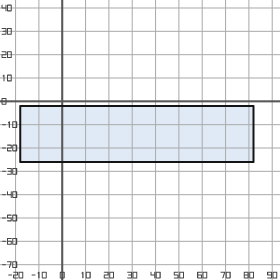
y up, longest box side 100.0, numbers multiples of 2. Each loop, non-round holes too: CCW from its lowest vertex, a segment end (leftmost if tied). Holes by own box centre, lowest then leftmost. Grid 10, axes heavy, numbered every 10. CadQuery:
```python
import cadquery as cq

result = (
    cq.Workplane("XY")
    .moveTo(-18.0, -26.0)
    .lineTo(82.0, -26.0)
    .lineTo(82.0, -2.0)
    .lineTo(-18.0, -2.0)
    .close()
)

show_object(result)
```